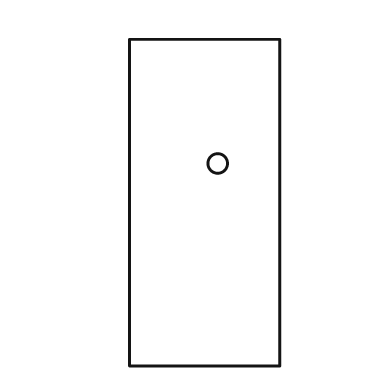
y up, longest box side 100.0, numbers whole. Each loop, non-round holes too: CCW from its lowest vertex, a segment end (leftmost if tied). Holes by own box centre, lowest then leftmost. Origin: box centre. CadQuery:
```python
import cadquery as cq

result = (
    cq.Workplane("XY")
    .moveTo(-23.0, -50.0)
    .lineTo(23.0, -50.0)
    .lineTo(23.0, 50.0)
    .lineTo(-23.0, 50.0)
    .close()
    .moveTo(4.0, 12.0)
    .circle(3.0)
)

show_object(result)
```